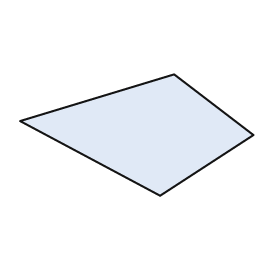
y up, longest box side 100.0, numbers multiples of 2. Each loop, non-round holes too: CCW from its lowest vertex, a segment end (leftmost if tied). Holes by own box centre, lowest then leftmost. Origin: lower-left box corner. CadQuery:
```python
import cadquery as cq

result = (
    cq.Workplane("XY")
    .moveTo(60.0, 0.0)
    .lineTo(100.0, 26.0)
    .lineTo(66.0, 52.0)
    .lineTo(0.0, 32.0)
    .close()
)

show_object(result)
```